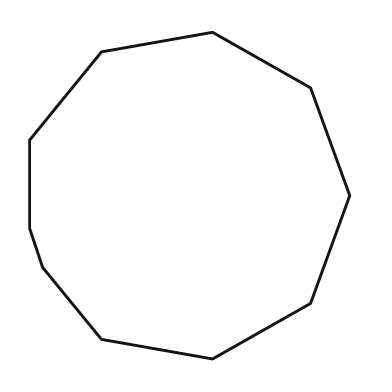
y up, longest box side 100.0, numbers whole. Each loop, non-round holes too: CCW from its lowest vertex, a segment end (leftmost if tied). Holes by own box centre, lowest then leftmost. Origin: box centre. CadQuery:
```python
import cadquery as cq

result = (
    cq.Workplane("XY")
    .moveTo(7.0, -50.0)
    .lineTo(37.0, -33.0)
    .lineTo(49.0, 0.0)
    .lineTo(37.0, 33.0)
    .lineTo(7.0, 50.0)
    .lineTo(-27.0, 44.0)
    .lineTo(-49.0, 17.0)
    .lineTo(-49.0, -10.0)
    .lineTo(-45.0, -22.0)
    .lineTo(-27.0, -44.0)
    .close()
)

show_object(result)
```